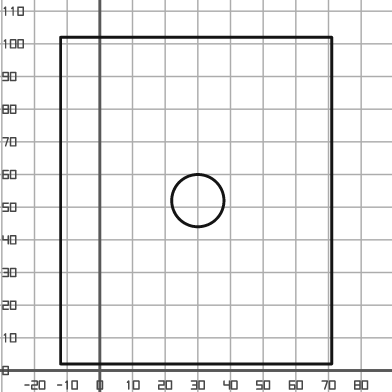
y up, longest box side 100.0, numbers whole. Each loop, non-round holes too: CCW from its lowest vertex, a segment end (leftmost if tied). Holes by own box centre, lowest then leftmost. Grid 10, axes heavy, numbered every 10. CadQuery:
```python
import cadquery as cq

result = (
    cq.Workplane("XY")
    .moveTo(-12.0, 2.0)
    .lineTo(71.0, 2.0)
    .lineTo(71.0, 102.0)
    .lineTo(-12.0, 102.0)
    .close()
    .moveTo(30.0, 52.0)
    .circle(8.0)
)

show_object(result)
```